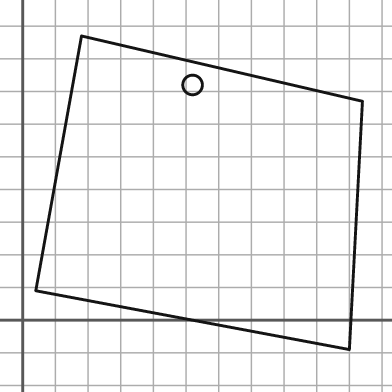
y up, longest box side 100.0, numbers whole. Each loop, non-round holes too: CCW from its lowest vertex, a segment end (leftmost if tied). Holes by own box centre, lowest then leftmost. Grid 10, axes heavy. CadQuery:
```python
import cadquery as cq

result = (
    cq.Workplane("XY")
    .moveTo(100.0, -9.0)
    .lineTo(104.0, 67.0)
    .lineTo(18.0, 87.0)
    .lineTo(4.0, 9.0)
    .close()
    .moveTo(52.0, 72.0)
    .circle(3.0)
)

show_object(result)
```